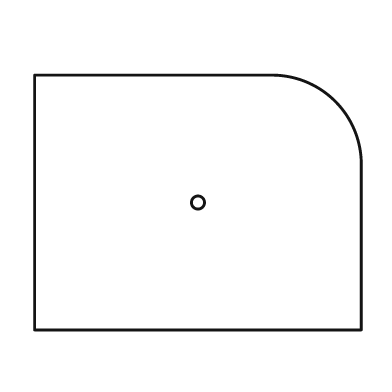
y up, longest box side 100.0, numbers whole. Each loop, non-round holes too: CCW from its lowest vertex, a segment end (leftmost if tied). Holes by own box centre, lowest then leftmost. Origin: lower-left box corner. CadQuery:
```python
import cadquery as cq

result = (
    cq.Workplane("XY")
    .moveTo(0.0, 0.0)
    .lineTo(100.0, 0.0)
    .lineTo(100.0, 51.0)
    .threePointArc((92.0, 70.0), (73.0, 78.0))
    .lineTo(0.0, 78.0)
    .close()
    .moveTo(50.0, 39.0)
    .circle(2.0)
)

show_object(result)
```